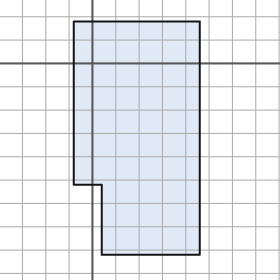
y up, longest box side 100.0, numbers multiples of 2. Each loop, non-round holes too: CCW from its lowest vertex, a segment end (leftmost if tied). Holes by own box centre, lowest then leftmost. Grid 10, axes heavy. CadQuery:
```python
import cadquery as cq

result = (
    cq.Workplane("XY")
    .moveTo(4.0, -82.0)
    .lineTo(46.0, -82.0)
    .lineTo(46.0, 18.0)
    .lineTo(-8.0, 18.0)
    .lineTo(-8.0, -52.0)
    .lineTo(4.0, -52.0)
    .close()
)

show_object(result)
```